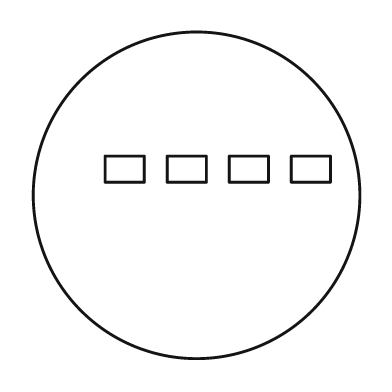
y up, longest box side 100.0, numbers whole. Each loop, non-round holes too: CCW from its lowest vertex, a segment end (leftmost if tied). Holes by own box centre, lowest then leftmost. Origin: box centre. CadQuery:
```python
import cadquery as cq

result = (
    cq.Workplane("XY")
    .moveTo(0.0, 0.0)
    .circle(50.0)
    .moveTo(-28.0, 4.0)
    .lineTo(-16.0, 4.0)
    .lineTo(-16.0, 12.0)
    .lineTo(-28.0, 12.0)
    .close()
    .moveTo(-9.0, 4.0)
    .lineTo(3.0, 4.0)
    .lineTo(3.0, 12.0)
    .lineTo(-9.0, 12.0)
    .close()
    .moveTo(10.0, 4.0)
    .lineTo(22.0, 4.0)
    .lineTo(22.0, 12.0)
    .lineTo(10.0, 12.0)
    .close()
    .moveTo(29.0, 4.0)
    .lineTo(41.0, 4.0)
    .lineTo(41.0, 12.0)
    .lineTo(29.0, 12.0)
    .close()
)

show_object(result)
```